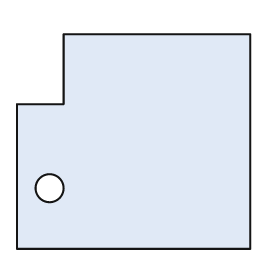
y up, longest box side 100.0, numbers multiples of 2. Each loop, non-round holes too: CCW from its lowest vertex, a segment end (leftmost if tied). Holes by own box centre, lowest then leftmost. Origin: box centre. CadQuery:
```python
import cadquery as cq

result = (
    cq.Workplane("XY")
    .moveTo(-50.0, -46.0)
    .lineTo(50.0, -46.0)
    .lineTo(50.0, 46.0)
    .lineTo(-30.0, 46.0)
    .lineTo(-30.0, 16.0)
    .lineTo(-50.0, 16.0)
    .close()
    .moveTo(-36.0, -20.0)
    .circle(6.0)
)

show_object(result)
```